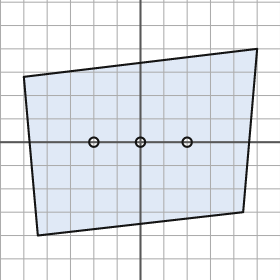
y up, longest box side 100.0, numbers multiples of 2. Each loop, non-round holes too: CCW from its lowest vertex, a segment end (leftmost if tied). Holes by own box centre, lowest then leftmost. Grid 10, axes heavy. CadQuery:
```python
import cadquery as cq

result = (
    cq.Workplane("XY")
    .moveTo(-44.0, -40.0)
    .lineTo(44.0, -30.0)
    .lineTo(50.0, 40.0)
    .lineTo(-50.0, 28.0)
    .close()
    .moveTo(-20.0, 0.0)
    .circle(2.0)
    .moveTo(0.0, 0.0)
    .circle(2.0)
    .moveTo(20.0, 0.0)
    .circle(2.0)
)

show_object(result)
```